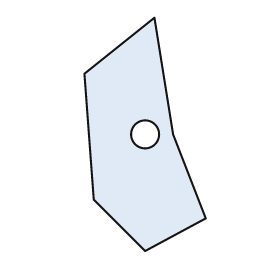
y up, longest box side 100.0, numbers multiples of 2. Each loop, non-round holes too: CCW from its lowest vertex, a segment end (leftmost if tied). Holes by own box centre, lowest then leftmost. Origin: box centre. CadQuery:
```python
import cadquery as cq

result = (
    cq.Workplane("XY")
    .moveTo(0.0, -50.0)
    .lineTo(26.0, -36.0)
    .lineTo(12.0, 0.0)
    .lineTo(4.0, 50.0)
    .lineTo(-26.0, 26.0)
    .lineTo(-22.0, -28.0)
    .close()
    .moveTo(0.0, 0.0)
    .circle(6.0)
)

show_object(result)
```